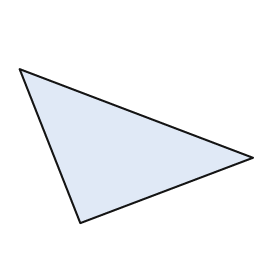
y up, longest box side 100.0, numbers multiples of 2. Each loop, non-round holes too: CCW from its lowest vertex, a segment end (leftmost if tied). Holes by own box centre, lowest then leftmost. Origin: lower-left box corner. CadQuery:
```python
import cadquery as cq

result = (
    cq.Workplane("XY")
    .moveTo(26.0, 0.0)
    .lineTo(100.0, 28.0)
    .lineTo(0.0, 66.0)
    .close()
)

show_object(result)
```